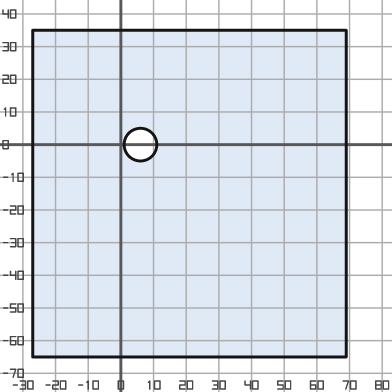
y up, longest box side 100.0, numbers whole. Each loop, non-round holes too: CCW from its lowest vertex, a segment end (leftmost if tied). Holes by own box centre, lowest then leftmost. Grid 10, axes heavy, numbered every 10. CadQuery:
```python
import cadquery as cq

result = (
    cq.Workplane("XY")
    .moveTo(-27.0, -65.0)
    .lineTo(69.0, -65.0)
    .lineTo(69.0, 35.0)
    .lineTo(-27.0, 35.0)
    .close()
    .moveTo(6.0, 0.0)
    .circle(5.0)
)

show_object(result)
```